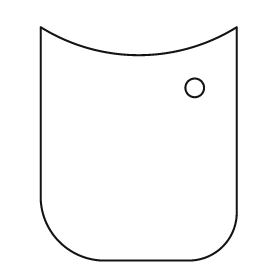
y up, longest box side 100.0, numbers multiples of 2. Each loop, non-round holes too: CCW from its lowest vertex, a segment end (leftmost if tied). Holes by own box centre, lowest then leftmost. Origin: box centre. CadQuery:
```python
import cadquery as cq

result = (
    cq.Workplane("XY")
    .moveTo(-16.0, -50.0)
    .lineTo(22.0, -50.0)
    .threePointArc((36.0, -44.0), (42.0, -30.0))
    .lineTo(42.0, 50.0)
    .threePointArc((0.0, 38.0), (-42.0, 50.0))
    .lineTo(-42.0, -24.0)
    .threePointArc((-34.0, -42.0), (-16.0, -50.0))
    .close()
    .moveTo(24.0, 24.0)
    .circle(4.0)
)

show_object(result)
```